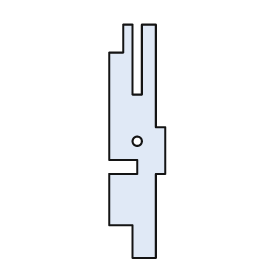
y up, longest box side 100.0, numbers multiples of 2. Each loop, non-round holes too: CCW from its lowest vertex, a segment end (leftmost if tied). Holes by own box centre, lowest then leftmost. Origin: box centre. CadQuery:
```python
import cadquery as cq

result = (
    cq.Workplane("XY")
    .moveTo(-2.0, -50.0)
    .lineTo(8.0, -50.0)
    .lineTo(8.0, -14.0)
    .lineTo(12.0, -14.0)
    .lineTo(12.0, 6.0)
    .lineTo(8.0, 6.0)
    .lineTo(8.0, 50.0)
    .lineTo(2.0, 50.0)
    .lineTo(2.0, 20.0)
    .lineTo(-2.0, 20.0)
    .lineTo(-2.0, 50.0)
    .lineTo(-6.0, 50.0)
    .lineTo(-6.0, 38.0)
    .lineTo(-12.0, 38.0)
    .lineTo(-12.0, -8.0)
    .lineTo(0.0, -8.0)
    .lineTo(0.0, -14.0)
    .lineTo(-12.0, -14.0)
    .lineTo(-12.0, -36.0)
    .lineTo(-2.0, -36.0)
    .close()
    .moveTo(0.0, 0.0)
    .circle(2.0)
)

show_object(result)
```